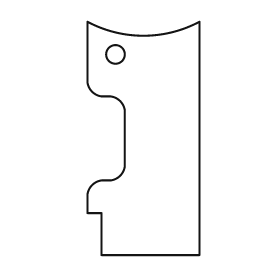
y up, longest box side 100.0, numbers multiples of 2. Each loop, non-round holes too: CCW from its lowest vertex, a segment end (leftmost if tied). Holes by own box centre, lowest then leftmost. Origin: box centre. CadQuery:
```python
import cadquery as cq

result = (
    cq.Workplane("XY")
    .moveTo(-18.0, -50.0)
    .lineTo(24.0, -50.0)
    .lineTo(24.0, 50.0)
    .threePointArc((0.0, 44.0), (-24.0, 50.0))
    .lineTo(-24.0, 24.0)
    .threePointArc((-22.0, 20.0), (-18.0, 18.0))
    .lineTo(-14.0, 18.0)
    .threePointArc((-10.0, 16.0), (-8.0, 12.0))
    .lineTo(-8.0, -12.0)
    .threePointArc((-10.0, -16.0), (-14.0, -18.0))
    .lineTo(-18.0, -18.0)
    .threePointArc((-22.0, -20.0), (-24.0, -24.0))
    .lineTo(-24.0, -32.0)
    .lineTo(-18.0, -32.0)
    .close()
    .moveTo(-12.0, 36.0)
    .circle(4.0)
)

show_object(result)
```